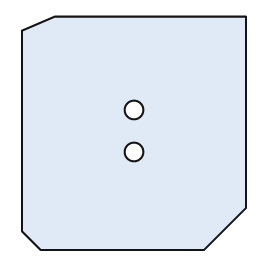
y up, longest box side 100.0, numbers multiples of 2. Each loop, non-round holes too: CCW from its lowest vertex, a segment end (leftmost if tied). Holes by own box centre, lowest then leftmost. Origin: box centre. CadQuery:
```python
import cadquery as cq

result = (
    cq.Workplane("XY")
    .moveTo(-40.0, -50.0)
    .lineTo(30.0, -50.0)
    .lineTo(48.0, -32.0)
    .lineTo(48.0, 50.0)
    .lineTo(-34.0, 50.0)
    .lineTo(-48.0, 44.0)
    .lineTo(-48.0, -42.0)
    .close()
    .moveTo(0.0, -8.0)
    .circle(4.0)
    .moveTo(0.0, 10.0)
    .circle(4.0)
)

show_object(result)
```